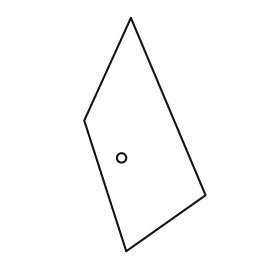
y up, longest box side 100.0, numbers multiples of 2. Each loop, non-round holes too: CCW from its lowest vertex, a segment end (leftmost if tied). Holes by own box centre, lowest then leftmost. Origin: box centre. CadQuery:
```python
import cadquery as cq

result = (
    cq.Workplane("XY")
    .moveTo(-8.0, -50.0)
    .lineTo(26.0, -26.0)
    .lineTo(-6.0, 50.0)
    .lineTo(-26.0, 6.0)
    .close()
    .moveTo(-10.0, -10.0)
    .circle(2.0)
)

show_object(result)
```